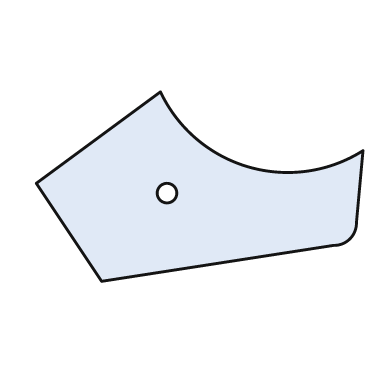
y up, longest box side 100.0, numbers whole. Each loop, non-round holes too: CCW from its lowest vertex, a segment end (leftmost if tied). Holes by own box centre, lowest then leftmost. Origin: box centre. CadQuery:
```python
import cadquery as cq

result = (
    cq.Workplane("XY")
    .moveTo(-30.0, -29.0)
    .lineTo(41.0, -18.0)
    .threePointArc((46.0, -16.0), (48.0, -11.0))
    .lineTo(50.0, 11.0)
    .threePointArc((15.0, 6.0), (-12.0, 29.0))
    .lineTo(-50.0, 1.0)
    .close()
    .moveTo(-10.0, -2.0)
    .circle(3.0)
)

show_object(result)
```